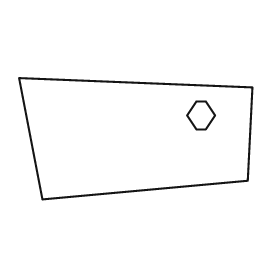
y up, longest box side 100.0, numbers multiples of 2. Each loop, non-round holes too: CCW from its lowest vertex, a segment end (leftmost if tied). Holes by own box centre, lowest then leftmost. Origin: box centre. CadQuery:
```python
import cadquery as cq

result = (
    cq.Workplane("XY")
    .moveTo(-40.0, -26.0)
    .lineTo(48.0, -18.0)
    .lineTo(50.0, 22.0)
    .lineTo(-50.0, 26.0)
    .close()
    .moveTo(26.0, 4.0)
    .lineTo(30.0, 4.0)
    .lineTo(34.0, 10.0)
    .lineTo(30.0, 16.0)
    .lineTo(26.0, 16.0)
    .lineTo(22.0, 10.0)
    .close()
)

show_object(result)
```